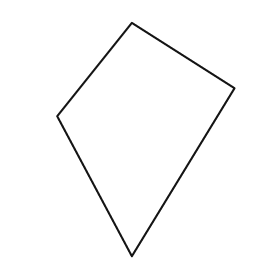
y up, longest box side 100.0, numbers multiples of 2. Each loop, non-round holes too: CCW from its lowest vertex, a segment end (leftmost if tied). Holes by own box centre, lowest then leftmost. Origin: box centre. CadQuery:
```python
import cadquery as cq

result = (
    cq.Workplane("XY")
    .moveTo(-6.0, -50.0)
    .lineTo(38.0, 22.0)
    .lineTo(-6.0, 50.0)
    .lineTo(-38.0, 10.0)
    .close()
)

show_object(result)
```